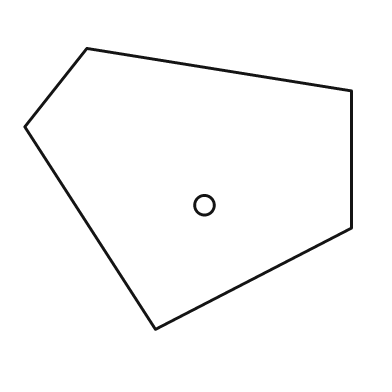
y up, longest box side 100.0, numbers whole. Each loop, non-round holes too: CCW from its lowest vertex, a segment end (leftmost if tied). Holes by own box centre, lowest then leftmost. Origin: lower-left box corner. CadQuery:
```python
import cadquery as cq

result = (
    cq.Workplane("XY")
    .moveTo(40.0, 0.0)
    .lineTo(100.0, 31.0)
    .lineTo(100.0, 73.0)
    .lineTo(19.0, 86.0)
    .lineTo(0.0, 62.0)
    .close()
    .moveTo(55.0, 38.0)
    .circle(3.0)
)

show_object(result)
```